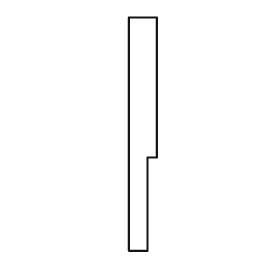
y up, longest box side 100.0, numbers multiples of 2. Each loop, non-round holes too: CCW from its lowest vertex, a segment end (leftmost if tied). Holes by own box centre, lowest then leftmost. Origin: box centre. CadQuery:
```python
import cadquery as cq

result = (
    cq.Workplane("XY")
    .moveTo(-6.0, -50.0)
    .lineTo(2.0, -50.0)
    .lineTo(2.0, -10.0)
    .lineTo(6.0, -10.0)
    .lineTo(6.0, 50.0)
    .lineTo(-6.0, 50.0)
    .close()
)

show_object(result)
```